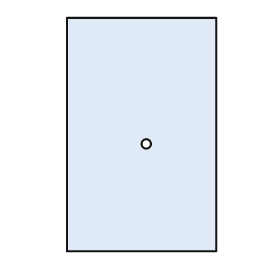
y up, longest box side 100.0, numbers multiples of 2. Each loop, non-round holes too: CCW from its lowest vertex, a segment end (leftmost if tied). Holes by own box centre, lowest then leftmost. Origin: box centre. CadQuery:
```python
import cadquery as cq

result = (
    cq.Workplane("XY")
    .moveTo(-32.0, -50.0)
    .lineTo(32.0, -50.0)
    .lineTo(32.0, 50.0)
    .lineTo(-32.0, 50.0)
    .close()
    .moveTo(2.0, -4.0)
    .circle(2.0)
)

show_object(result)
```